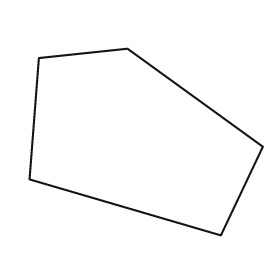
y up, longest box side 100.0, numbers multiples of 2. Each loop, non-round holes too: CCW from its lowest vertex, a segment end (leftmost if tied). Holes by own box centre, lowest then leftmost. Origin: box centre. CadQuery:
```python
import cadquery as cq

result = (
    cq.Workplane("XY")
    .moveTo(32.0, -40.0)
    .lineTo(50.0, -2.0)
    .lineTo(-8.0, 40.0)
    .lineTo(-46.0, 36.0)
    .lineTo(-50.0, -16.0)
    .close()
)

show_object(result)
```